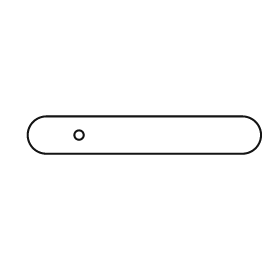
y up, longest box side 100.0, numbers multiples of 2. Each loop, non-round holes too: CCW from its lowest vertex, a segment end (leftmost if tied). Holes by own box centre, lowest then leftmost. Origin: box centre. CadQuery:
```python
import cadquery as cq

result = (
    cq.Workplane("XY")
    .moveTo(-42.0, -8.0)
    .lineTo(42.0, -8.0)
    .threePointArc((50.0, 0.0), (42.0, 8.0))
    .lineTo(-42.0, 8.0)
    .threePointArc((-50.0, 0.0), (-42.0, -8.0))
    .close()
    .moveTo(-28.0, 0.0)
    .circle(2.0)
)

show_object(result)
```